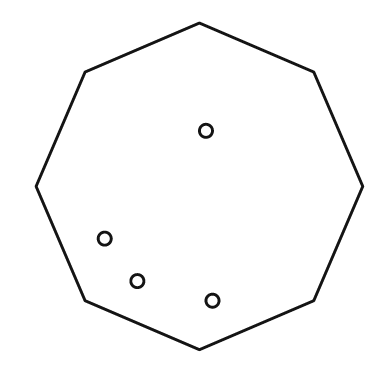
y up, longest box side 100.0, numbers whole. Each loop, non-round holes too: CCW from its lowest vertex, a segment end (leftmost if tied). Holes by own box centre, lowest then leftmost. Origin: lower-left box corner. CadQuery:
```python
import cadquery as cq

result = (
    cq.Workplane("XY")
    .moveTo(50.0, 0.0)
    .lineTo(85.0, 15.0)
    .lineTo(100.0, 50.0)
    .lineTo(85.0, 85.0)
    .lineTo(50.0, 100.0)
    .lineTo(15.0, 85.0)
    .lineTo(0.0, 50.0)
    .lineTo(15.0, 15.0)
    .close()
    .moveTo(54.0, 15.0)
    .circle(2.0)
    .moveTo(31.0, 21.0)
    .circle(2.0)
    .moveTo(21.0, 34.0)
    .circle(2.0)
    .moveTo(52.0, 67.0)
    .circle(2.0)
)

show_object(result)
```